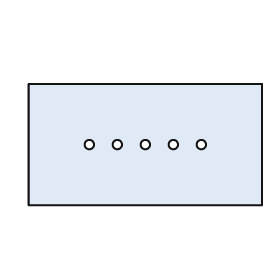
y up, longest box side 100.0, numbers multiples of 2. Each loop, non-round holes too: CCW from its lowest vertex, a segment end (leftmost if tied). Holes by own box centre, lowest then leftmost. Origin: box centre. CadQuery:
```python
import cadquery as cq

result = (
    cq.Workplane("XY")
    .moveTo(-50.0, -26.0)
    .lineTo(50.0, -26.0)
    .lineTo(50.0, 26.0)
    .lineTo(-50.0, 26.0)
    .close()
    .moveTo(-24.0, 0.0)
    .circle(2.0)
    .moveTo(-12.0, 0.0)
    .circle(2.0)
    .moveTo(0.0, 0.0)
    .circle(2.0)
    .moveTo(12.0, 0.0)
    .circle(2.0)
    .moveTo(24.0, 0.0)
    .circle(2.0)
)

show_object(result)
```